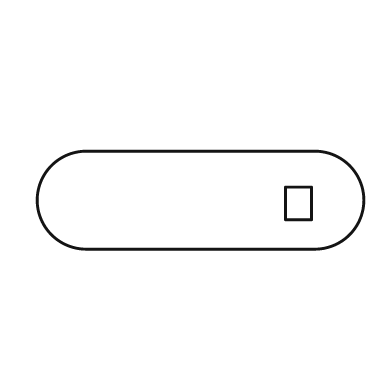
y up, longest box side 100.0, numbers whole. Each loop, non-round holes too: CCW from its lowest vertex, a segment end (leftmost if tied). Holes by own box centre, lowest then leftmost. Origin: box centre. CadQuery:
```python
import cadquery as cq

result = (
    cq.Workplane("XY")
    .moveTo(-35.0, -15.0)
    .lineTo(35.0, -15.0)
    .threePointArc((50.0, 0.0), (35.0, 15.0))
    .lineTo(-35.0, 15.0)
    .threePointArc((-50.0, 0.0), (-35.0, -15.0))
    .close()
    .moveTo(26.0, -6.0)
    .lineTo(34.0, -6.0)
    .lineTo(34.0, 4.0)
    .lineTo(26.0, 4.0)
    .close()
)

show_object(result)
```